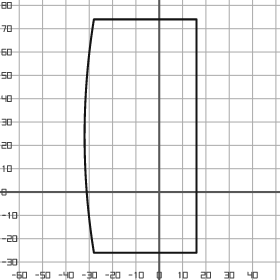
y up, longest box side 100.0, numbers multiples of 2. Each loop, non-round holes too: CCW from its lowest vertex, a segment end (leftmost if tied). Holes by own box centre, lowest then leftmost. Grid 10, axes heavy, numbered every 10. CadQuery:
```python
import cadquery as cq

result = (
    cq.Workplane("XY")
    .moveTo(-28.0, -26.0)
    .lineTo(16.0, -26.0)
    .lineTo(16.0, 74.0)
    .lineTo(-28.0, 74.0)
    .threePointArc((-32.0, 24.0), (-28.0, -26.0))
    .close()
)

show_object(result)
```